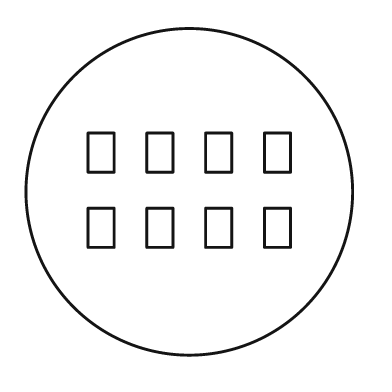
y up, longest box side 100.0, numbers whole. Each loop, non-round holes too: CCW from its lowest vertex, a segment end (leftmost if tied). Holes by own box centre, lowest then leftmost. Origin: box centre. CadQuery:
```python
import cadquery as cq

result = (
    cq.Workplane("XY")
    .moveTo(0.0, 0.0)
    .circle(50.0)
    .moveTo(-31.0, -17.0)
    .lineTo(-23.0, -17.0)
    .lineTo(-23.0, -5.0)
    .lineTo(-31.0, -5.0)
    .close()
    .moveTo(-13.0, -17.0)
    .lineTo(-5.0, -17.0)
    .lineTo(-5.0, -5.0)
    .lineTo(-13.0, -5.0)
    .close()
    .moveTo(5.0, -17.0)
    .lineTo(13.0, -17.0)
    .lineTo(13.0, -5.0)
    .lineTo(5.0, -5.0)
    .close()
    .moveTo(23.0, -17.0)
    .lineTo(31.0, -17.0)
    .lineTo(31.0, -5.0)
    .lineTo(23.0, -5.0)
    .close()
    .moveTo(-31.0, 6.0)
    .lineTo(-23.0, 6.0)
    .lineTo(-23.0, 18.0)
    .lineTo(-31.0, 18.0)
    .close()
    .moveTo(-13.0, 6.0)
    .lineTo(-5.0, 6.0)
    .lineTo(-5.0, 18.0)
    .lineTo(-13.0, 18.0)
    .close()
    .moveTo(5.0, 6.0)
    .lineTo(13.0, 6.0)
    .lineTo(13.0, 18.0)
    .lineTo(5.0, 18.0)
    .close()
    .moveTo(23.0, 6.0)
    .lineTo(31.0, 6.0)
    .lineTo(31.0, 18.0)
    .lineTo(23.0, 18.0)
    .close()
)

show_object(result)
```